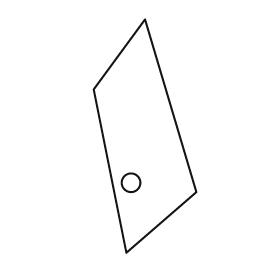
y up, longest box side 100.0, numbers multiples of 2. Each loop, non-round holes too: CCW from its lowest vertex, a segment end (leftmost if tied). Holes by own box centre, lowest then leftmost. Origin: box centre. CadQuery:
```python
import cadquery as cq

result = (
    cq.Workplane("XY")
    .moveTo(-8.0, -50.0)
    .lineTo(22.0, -24.0)
    .lineTo(0.0, 50.0)
    .lineTo(-22.0, 20.0)
    .close()
    .moveTo(-6.0, -20.0)
    .circle(4.0)
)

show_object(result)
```